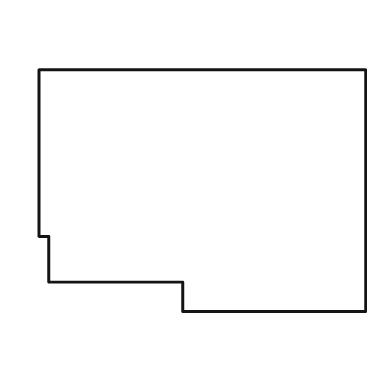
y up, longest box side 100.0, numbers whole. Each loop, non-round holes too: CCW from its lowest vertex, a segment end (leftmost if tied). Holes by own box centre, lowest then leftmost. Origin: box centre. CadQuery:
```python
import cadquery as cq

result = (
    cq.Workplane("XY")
    .moveTo(-6.0, -37.0)
    .lineTo(50.0, -37.0)
    .lineTo(50.0, 37.0)
    .lineTo(-50.0, 37.0)
    .lineTo(-50.0, -14.0)
    .lineTo(-47.0, -14.0)
    .lineTo(-47.0, -28.0)
    .lineTo(-6.0, -28.0)
    .close()
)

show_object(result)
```